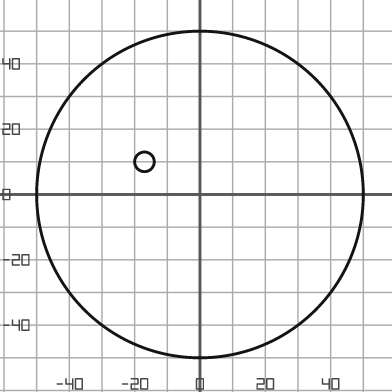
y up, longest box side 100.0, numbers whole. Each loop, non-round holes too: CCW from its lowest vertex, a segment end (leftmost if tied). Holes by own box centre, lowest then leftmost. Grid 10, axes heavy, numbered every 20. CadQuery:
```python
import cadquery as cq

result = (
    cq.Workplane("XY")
    .moveTo(0.0, 0.0)
    .circle(50.0)
    .moveTo(-17.0, 10.0)
    .circle(3.0)
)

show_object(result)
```